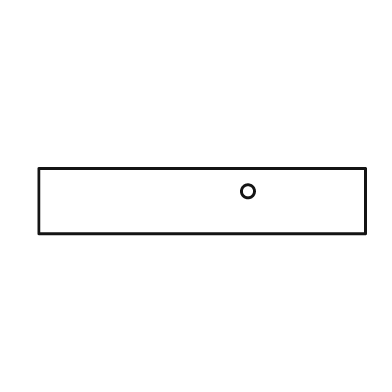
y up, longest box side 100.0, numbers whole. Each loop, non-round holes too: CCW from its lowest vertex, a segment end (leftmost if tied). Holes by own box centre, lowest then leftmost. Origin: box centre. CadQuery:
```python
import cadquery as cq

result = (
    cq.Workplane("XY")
    .moveTo(-50.0, -10.0)
    .lineTo(50.0, -10.0)
    .lineTo(50.0, 10.0)
    .lineTo(-50.0, 10.0)
    .close()
    .moveTo(14.0, 3.0)
    .circle(2.0)
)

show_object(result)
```